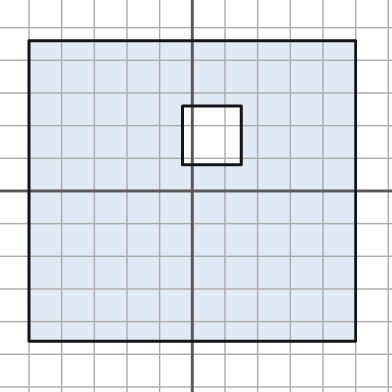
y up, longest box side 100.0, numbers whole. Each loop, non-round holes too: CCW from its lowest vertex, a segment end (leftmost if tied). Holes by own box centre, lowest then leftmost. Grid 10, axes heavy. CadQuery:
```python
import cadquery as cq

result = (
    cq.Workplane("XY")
    .moveTo(-50.0, -46.0)
    .lineTo(50.0, -46.0)
    .lineTo(50.0, 46.0)
    .lineTo(-50.0, 46.0)
    .close()
    .moveTo(-3.0, 8.0)
    .lineTo(15.0, 8.0)
    .lineTo(15.0, 26.0)
    .lineTo(-3.0, 26.0)
    .close()
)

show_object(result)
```